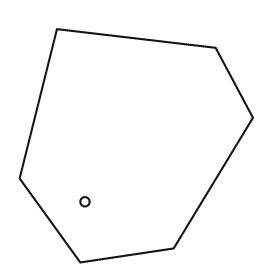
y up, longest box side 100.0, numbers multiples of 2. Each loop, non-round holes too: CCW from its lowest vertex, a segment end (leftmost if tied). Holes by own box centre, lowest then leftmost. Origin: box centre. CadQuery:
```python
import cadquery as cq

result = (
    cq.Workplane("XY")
    .moveTo(-24.0, -50.0)
    .lineTo(16.0, -44.0)
    .lineTo(50.0, 12.0)
    .lineTo(34.0, 42.0)
    .lineTo(-34.0, 50.0)
    .lineTo(-50.0, -14.0)
    .close()
    .moveTo(-22.0, -24.0)
    .circle(2.0)
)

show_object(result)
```